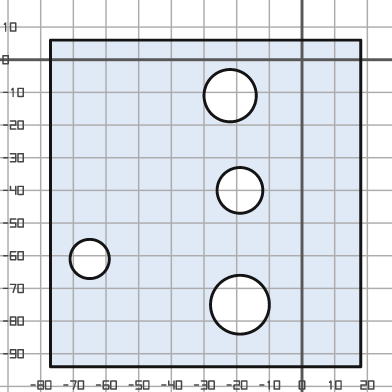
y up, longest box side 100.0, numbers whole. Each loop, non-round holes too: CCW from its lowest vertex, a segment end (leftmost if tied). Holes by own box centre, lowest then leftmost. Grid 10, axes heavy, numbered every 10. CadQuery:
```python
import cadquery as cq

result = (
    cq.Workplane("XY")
    .moveTo(-77.0, -94.0)
    .lineTo(18.0, -94.0)
    .lineTo(18.0, 6.0)
    .lineTo(-77.0, 6.0)
    .close()
    .moveTo(-19.0, -75.0)
    .circle(9.0)
    .moveTo(-65.0, -61.0)
    .circle(6.0)
    .moveTo(-19.0, -40.0)
    .circle(7.0)
    .moveTo(-22.0, -11.0)
    .circle(8.0)
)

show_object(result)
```